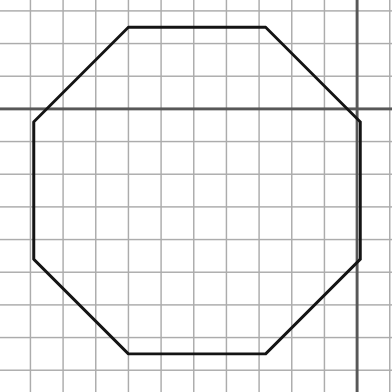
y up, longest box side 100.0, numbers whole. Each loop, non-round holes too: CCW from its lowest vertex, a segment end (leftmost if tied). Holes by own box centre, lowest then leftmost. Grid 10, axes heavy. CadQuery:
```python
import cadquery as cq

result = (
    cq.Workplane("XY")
    .moveTo(-70.0, -75.0)
    .lineTo(-28.0, -75.0)
    .lineTo(1.0, -46.0)
    .lineTo(1.0, -4.0)
    .lineTo(-28.0, 25.0)
    .lineTo(-70.0, 25.0)
    .lineTo(-99.0, -4.0)
    .lineTo(-99.0, -46.0)
    .close()
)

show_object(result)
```